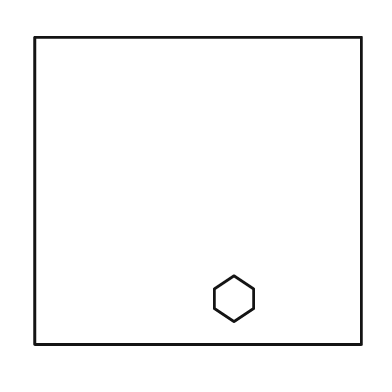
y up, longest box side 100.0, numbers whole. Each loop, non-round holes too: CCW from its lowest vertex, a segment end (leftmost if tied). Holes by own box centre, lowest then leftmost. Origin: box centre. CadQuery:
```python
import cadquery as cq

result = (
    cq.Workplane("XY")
    .moveTo(-50.0, -47.0)
    .lineTo(50.0, -47.0)
    .lineTo(50.0, 47.0)
    .lineTo(-50.0, 47.0)
    .close()
    .moveTo(11.0, -40.0)
    .lineTo(17.0, -36.0)
    .lineTo(17.0, -30.0)
    .lineTo(11.0, -26.0)
    .lineTo(5.0, -30.0)
    .lineTo(5.0, -36.0)
    .close()
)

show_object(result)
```